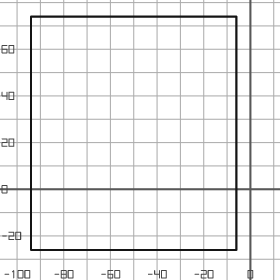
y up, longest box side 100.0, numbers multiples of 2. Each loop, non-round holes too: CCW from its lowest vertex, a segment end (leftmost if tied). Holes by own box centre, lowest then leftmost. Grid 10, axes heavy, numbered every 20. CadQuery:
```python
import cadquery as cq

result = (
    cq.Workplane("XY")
    .moveTo(-94.0, -26.0)
    .lineTo(-6.0, -26.0)
    .lineTo(-6.0, 74.0)
    .lineTo(-94.0, 74.0)
    .close()
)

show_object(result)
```